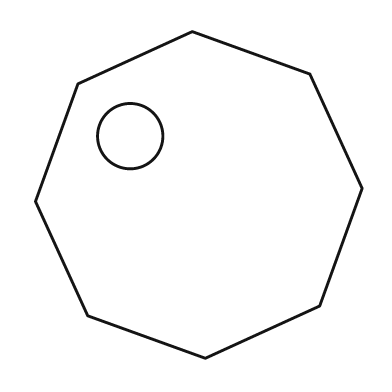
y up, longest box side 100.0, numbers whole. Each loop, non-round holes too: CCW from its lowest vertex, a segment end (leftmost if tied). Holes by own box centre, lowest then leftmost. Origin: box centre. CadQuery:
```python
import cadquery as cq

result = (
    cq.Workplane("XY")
    .moveTo(2.0, -50.0)
    .lineTo(37.0, -34.0)
    .lineTo(50.0, 2.0)
    .lineTo(34.0, 37.0)
    .lineTo(-2.0, 50.0)
    .lineTo(-37.0, 34.0)
    .lineTo(-50.0, -2.0)
    .lineTo(-34.0, -37.0)
    .close()
    .moveTo(-21.0, 18.0)
    .circle(10.0)
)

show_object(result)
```